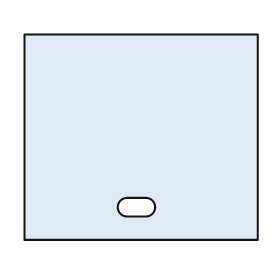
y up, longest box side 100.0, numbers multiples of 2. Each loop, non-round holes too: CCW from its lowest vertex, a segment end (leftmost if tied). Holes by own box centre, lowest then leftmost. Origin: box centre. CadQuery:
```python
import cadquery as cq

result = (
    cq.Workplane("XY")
    .moveTo(-50.0, -44.0)
    .lineTo(50.0, -44.0)
    .lineTo(50.0, 44.0)
    .lineTo(-50.0, 44.0)
    .close()
    .moveTo(-6.0, -34.0)
    .lineTo(2.0, -34.0)
    .threePointArc((6.0, -30.0), (2.0, -26.0))
    .lineTo(-6.0, -26.0)
    .threePointArc((-10.0, -30.0), (-6.0, -34.0))
    .close()
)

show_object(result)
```